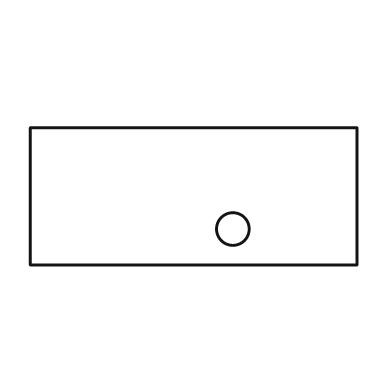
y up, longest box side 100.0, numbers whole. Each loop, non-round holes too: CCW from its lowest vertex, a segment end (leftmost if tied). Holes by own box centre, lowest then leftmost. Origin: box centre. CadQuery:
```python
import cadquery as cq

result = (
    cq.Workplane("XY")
    .moveTo(-50.0, -21.0)
    .lineTo(50.0, -21.0)
    .lineTo(50.0, 21.0)
    .lineTo(-50.0, 21.0)
    .close()
    .moveTo(12.0, -10.0)
    .circle(5.0)
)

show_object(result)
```